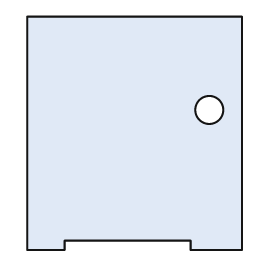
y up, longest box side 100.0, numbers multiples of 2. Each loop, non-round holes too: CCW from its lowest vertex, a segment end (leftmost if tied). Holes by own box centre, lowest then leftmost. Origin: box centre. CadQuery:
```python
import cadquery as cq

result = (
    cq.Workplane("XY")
    .moveTo(-46.0, -50.0)
    .lineTo(-30.0, -50.0)
    .lineTo(-30.0, -46.0)
    .lineTo(24.0, -46.0)
    .lineTo(24.0, -50.0)
    .lineTo(46.0, -50.0)
    .lineTo(46.0, 50.0)
    .lineTo(-46.0, 50.0)
    .close()
    .moveTo(32.0, 10.0)
    .circle(6.0)
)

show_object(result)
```